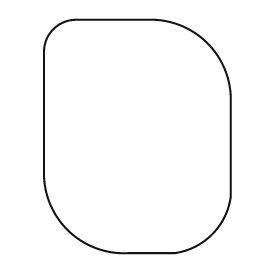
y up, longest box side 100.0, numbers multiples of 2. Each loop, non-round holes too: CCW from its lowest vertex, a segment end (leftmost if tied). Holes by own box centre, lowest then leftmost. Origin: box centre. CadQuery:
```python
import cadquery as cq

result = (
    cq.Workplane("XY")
    .moveTo(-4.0, -50.0)
    .lineTo(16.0, -50.0)
    .threePointArc((32.0, -42.0), (40.0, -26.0))
    .lineTo(40.0, 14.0)
    .threePointArc((30.0, 40.0), (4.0, 50.0))
    .lineTo(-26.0, 50.0)
    .threePointArc((-36.0, 46.0), (-40.0, 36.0))
    .lineTo(-40.0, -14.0)
    .threePointArc((-30.0, -40.0), (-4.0, -50.0))
    .close()
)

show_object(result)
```